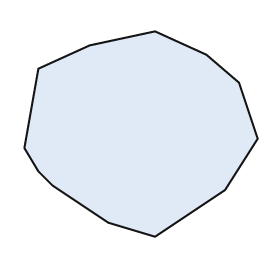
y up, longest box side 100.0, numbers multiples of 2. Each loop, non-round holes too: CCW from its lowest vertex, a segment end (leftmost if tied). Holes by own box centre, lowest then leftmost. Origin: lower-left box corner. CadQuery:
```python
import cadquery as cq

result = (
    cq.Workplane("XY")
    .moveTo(56.0, 0.0)
    .lineTo(86.0, 20.0)
    .lineTo(100.0, 42.0)
    .lineTo(92.0, 66.0)
    .lineTo(78.0, 78.0)
    .lineTo(56.0, 88.0)
    .lineTo(28.0, 82.0)
    .lineTo(6.0, 72.0)
    .lineTo(0.0, 38.0)
    .lineTo(6.0, 28.0)
    .lineTo(12.0, 22.0)
    .lineTo(36.0, 6.0)
    .close()
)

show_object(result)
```